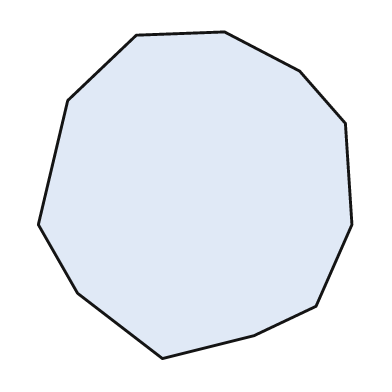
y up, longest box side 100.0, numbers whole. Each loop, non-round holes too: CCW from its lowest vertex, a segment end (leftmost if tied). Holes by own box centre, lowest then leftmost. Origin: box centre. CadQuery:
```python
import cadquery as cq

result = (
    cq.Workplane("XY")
    .moveTo(-10.0, -50.0)
    .lineTo(18.0, -43.0)
    .lineTo(37.0, -34.0)
    .lineTo(48.0, -9.0)
    .lineTo(46.0, 22.0)
    .lineTo(32.0, 38.0)
    .lineTo(9.0, 50.0)
    .lineTo(-18.0, 49.0)
    .lineTo(-39.0, 29.0)
    .lineTo(-48.0, -9.0)
    .lineTo(-36.0, -30.0)
    .close()
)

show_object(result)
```